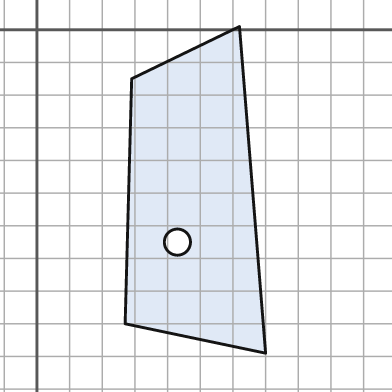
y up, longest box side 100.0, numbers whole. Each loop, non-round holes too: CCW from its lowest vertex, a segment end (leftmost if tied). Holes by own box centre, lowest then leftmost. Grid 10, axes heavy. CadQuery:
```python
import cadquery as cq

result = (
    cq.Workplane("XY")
    .moveTo(70.0, -99.0)
    .lineTo(62.0, 1.0)
    .lineTo(29.0, -15.0)
    .lineTo(27.0, -90.0)
    .close()
    .moveTo(43.0, -65.0)
    .circle(4.0)
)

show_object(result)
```